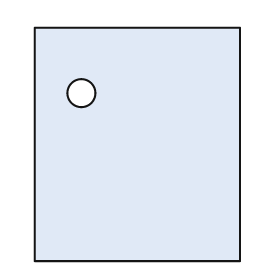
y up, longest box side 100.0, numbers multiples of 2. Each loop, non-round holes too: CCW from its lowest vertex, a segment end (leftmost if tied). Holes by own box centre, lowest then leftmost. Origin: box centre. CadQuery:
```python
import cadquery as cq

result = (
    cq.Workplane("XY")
    .moveTo(-44.0, -50.0)
    .lineTo(44.0, -50.0)
    .lineTo(44.0, 50.0)
    .lineTo(-44.0, 50.0)
    .close()
    .moveTo(-24.0, 22.0)
    .circle(6.0)
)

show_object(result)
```